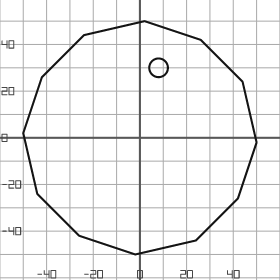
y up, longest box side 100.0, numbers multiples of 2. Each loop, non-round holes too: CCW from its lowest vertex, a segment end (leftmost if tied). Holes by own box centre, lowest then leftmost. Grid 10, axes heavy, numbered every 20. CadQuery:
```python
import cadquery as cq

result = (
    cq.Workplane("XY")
    .moveTo(-2.0, -50.0)
    .lineTo(24.0, -44.0)
    .lineTo(42.0, -26.0)
    .lineTo(50.0, -2.0)
    .lineTo(44.0, 24.0)
    .lineTo(26.0, 42.0)
    .lineTo(2.0, 50.0)
    .lineTo(-24.0, 44.0)
    .lineTo(-42.0, 26.0)
    .lineTo(-50.0, 2.0)
    .lineTo(-44.0, -24.0)
    .lineTo(-26.0, -42.0)
    .close()
    .moveTo(8.0, 30.0)
    .circle(4.0)
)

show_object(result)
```